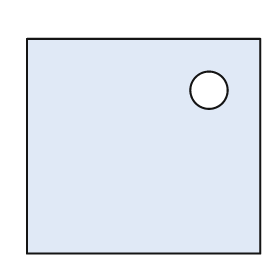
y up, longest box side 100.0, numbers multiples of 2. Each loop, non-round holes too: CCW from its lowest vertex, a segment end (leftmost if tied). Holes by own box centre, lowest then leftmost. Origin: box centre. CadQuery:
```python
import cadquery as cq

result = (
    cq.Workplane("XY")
    .moveTo(-50.0, -46.0)
    .lineTo(50.0, -46.0)
    .lineTo(50.0, 46.0)
    .lineTo(-50.0, 46.0)
    .close()
    .moveTo(28.0, 24.0)
    .circle(8.0)
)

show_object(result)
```